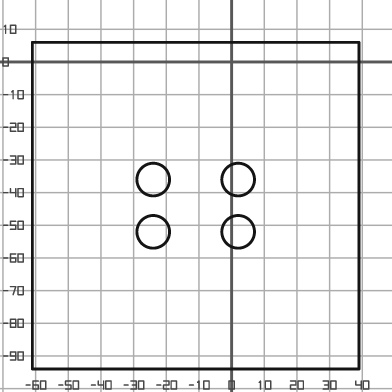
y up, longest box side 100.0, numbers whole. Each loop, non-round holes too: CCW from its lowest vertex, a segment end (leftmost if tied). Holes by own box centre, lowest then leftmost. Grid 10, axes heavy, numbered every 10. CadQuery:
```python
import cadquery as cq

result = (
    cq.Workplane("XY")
    .moveTo(-61.0, -94.0)
    .lineTo(39.0, -94.0)
    .lineTo(39.0, 6.0)
    .lineTo(-61.0, 6.0)
    .close()
    .moveTo(-24.0, -52.0)
    .circle(5.0)
    .moveTo(2.0, -52.0)
    .circle(5.0)
    .moveTo(-24.0, -36.0)
    .circle(5.0)
    .moveTo(2.0, -36.0)
    .circle(5.0)
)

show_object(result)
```